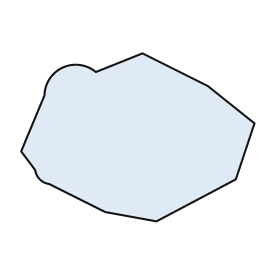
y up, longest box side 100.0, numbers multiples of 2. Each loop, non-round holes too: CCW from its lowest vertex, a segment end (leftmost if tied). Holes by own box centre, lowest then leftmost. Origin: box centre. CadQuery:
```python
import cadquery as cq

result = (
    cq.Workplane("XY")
    .moveTo(8.0, -36.0)
    .lineTo(42.0, -18.0)
    .lineTo(50.0, 6.0)
    .lineTo(30.0, 22.0)
    .lineTo(2.0, 36.0)
    .lineTo(-18.0, 28.0)
    .threePointArc((-32.0, 30.0), (-40.0, 18.0))
    .lineTo(-50.0, -6.0)
    .lineTo(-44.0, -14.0)
    .threePointArc((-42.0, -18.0), (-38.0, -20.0))
    .lineTo(-14.0, -32.0)
    .close()
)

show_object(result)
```